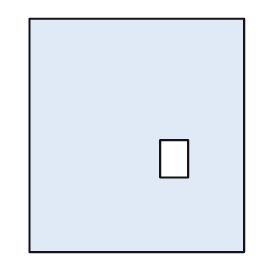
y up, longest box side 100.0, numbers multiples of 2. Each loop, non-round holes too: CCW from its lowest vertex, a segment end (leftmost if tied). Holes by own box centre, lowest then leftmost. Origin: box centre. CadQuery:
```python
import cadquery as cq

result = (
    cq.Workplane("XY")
    .moveTo(-46.0, -50.0)
    .lineTo(46.0, -50.0)
    .lineTo(46.0, 50.0)
    .lineTo(-46.0, 50.0)
    .close()
    .moveTo(10.0, -18.0)
    .lineTo(22.0, -18.0)
    .lineTo(22.0, -2.0)
    .lineTo(10.0, -2.0)
    .close()
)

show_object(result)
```